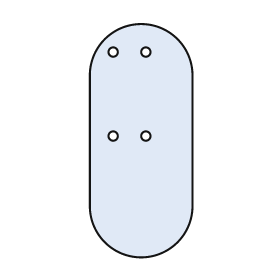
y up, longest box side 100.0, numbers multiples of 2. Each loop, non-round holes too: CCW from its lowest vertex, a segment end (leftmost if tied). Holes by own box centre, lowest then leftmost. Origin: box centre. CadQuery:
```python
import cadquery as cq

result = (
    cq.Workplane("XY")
    .moveTo(-22.0, -28.0)
    .threePointArc((0.0, -50.0), (22.0, -28.0))
    .lineTo(22.0, 28.0)
    .threePointArc((0.0, 50.0), (-22.0, 28.0))
    .close()
    .moveTo(-12.0, 2.0)
    .circle(2.0)
    .moveTo(2.0, 2.0)
    .circle(2.0)
    .moveTo(-12.0, 38.0)
    .circle(2.0)
    .moveTo(2.0, 38.0)
    .circle(2.0)
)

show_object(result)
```